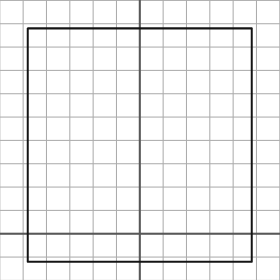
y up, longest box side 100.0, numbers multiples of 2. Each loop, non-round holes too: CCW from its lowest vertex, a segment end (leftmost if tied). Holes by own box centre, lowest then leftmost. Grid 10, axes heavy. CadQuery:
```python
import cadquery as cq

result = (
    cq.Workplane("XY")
    .moveTo(-48.0, -12.0)
    .lineTo(48.0, -12.0)
    .lineTo(48.0, 88.0)
    .lineTo(-48.0, 88.0)
    .close()
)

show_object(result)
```